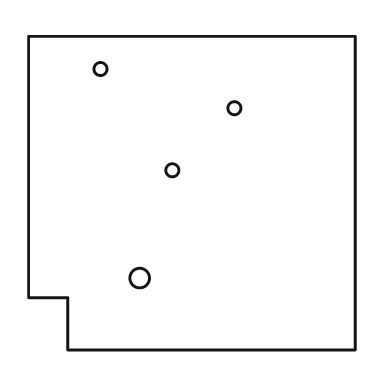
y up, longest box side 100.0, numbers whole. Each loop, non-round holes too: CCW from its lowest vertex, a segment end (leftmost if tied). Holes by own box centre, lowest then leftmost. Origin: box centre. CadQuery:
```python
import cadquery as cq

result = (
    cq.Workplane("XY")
    .moveTo(-38.0, -48.0)
    .lineTo(50.0, -48.0)
    .lineTo(50.0, 48.0)
    .lineTo(-50.0, 48.0)
    .lineTo(-50.0, -32.0)
    .lineTo(-38.0, -32.0)
    .close()
    .moveTo(-16.0, -26.0)
    .circle(3.0)
    .moveTo(-6.0, 7.0)
    .circle(2.0)
    .moveTo(13.0, 26.0)
    .circle(2.0)
    .moveTo(-28.0, 38.0)
    .circle(2.0)
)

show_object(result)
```